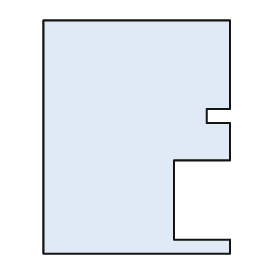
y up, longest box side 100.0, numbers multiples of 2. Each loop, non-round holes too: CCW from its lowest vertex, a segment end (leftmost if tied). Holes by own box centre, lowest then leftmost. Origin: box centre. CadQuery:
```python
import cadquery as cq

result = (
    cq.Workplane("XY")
    .moveTo(-40.0, -50.0)
    .lineTo(40.0, -50.0)
    .lineTo(40.0, -44.0)
    .lineTo(16.0, -44.0)
    .lineTo(16.0, -10.0)
    .lineTo(40.0, -10.0)
    .lineTo(40.0, 6.0)
    .lineTo(30.0, 6.0)
    .lineTo(30.0, 12.0)
    .lineTo(40.0, 12.0)
    .lineTo(40.0, 50.0)
    .lineTo(-40.0, 50.0)
    .close()
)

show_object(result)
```